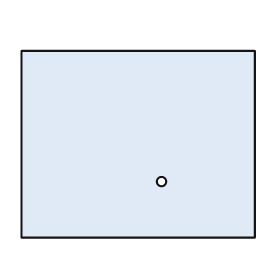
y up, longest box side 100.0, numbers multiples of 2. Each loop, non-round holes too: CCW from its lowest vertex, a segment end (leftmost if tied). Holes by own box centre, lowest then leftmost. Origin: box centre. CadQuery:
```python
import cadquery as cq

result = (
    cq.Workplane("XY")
    .moveTo(-50.0, -40.0)
    .lineTo(50.0, -40.0)
    .lineTo(50.0, 40.0)
    .lineTo(-50.0, 40.0)
    .close()
    .moveTo(10.0, -16.0)
    .circle(2.0)
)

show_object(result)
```